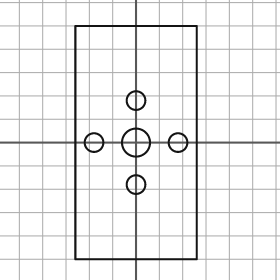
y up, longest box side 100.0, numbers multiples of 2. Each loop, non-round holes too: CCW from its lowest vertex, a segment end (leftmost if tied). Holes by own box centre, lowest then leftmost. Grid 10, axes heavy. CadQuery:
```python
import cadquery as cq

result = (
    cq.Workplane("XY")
    .moveTo(-26.0, -50.0)
    .lineTo(26.0, -50.0)
    .lineTo(26.0, 50.0)
    .lineTo(-26.0, 50.0)
    .close()
    .moveTo(0.0, -18.0)
    .circle(4.0)
    .moveTo(-18.0, 0.0)
    .circle(4.0)
    .moveTo(0.0, 0.0)
    .circle(6.0)
    .moveTo(18.0, 0.0)
    .circle(4.0)
    .moveTo(0.0, 18.0)
    .circle(4.0)
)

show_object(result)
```